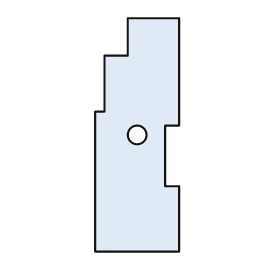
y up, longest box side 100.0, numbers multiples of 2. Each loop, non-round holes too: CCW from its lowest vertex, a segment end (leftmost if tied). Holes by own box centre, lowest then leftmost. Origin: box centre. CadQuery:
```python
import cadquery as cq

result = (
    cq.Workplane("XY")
    .moveTo(-18.0, -50.0)
    .lineTo(18.0, -50.0)
    .lineTo(18.0, -22.0)
    .lineTo(12.0, -22.0)
    .lineTo(12.0, 4.0)
    .lineTo(18.0, 4.0)
    .lineTo(18.0, 50.0)
    .lineTo(-4.0, 50.0)
    .lineTo(-4.0, 34.0)
    .lineTo(-14.0, 34.0)
    .lineTo(-14.0, 10.0)
    .lineTo(-18.0, 10.0)
    .close()
    .moveTo(0.0, 0.0)
    .circle(4.0)
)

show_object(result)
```